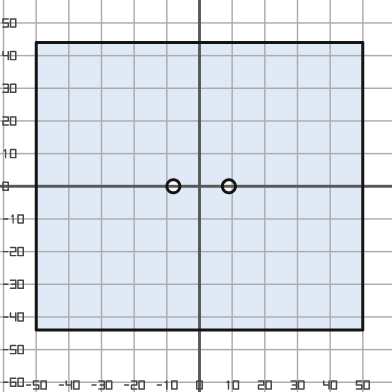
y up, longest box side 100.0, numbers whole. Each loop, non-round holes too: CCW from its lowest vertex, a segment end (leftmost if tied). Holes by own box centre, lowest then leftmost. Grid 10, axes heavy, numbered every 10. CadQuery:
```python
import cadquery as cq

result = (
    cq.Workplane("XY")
    .moveTo(-50.0, -44.0)
    .lineTo(50.0, -44.0)
    .lineTo(50.0, 44.0)
    .lineTo(-50.0, 44.0)
    .close()
    .moveTo(-8.0, 0.0)
    .circle(2.0)
    .moveTo(9.0, 0.0)
    .circle(2.0)
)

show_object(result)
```